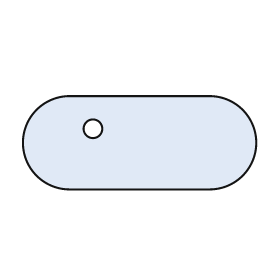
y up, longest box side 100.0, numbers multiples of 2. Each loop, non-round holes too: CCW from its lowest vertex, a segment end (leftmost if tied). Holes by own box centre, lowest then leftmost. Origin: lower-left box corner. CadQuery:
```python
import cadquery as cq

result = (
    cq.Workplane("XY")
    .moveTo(20.0, 0.0)
    .lineTo(80.0, 0.0)
    .threePointArc((100.0, 20.0), (80.0, 40.0))
    .lineTo(20.0, 40.0)
    .threePointArc((0.0, 20.0), (20.0, 0.0))
    .close()
    .moveTo(30.0, 26.0)
    .circle(4.0)
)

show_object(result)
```